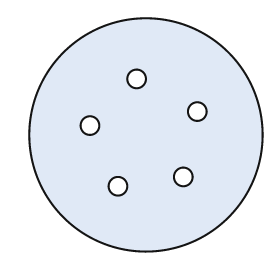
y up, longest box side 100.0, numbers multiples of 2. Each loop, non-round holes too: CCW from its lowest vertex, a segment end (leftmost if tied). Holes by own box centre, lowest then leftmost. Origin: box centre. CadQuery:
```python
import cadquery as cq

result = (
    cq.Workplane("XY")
    .moveTo(0.0, 0.0)
    .circle(50.0)
    .moveTo(-12.0, -22.0)
    .circle(4.0)
    .moveTo(16.0, -18.0)
    .circle(4.0)
    .moveTo(-24.0, 4.0)
    .circle(4.0)
    .moveTo(22.0, 10.0)
    .circle(4.0)
    .moveTo(-4.0, 24.0)
    .circle(4.0)
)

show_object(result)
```